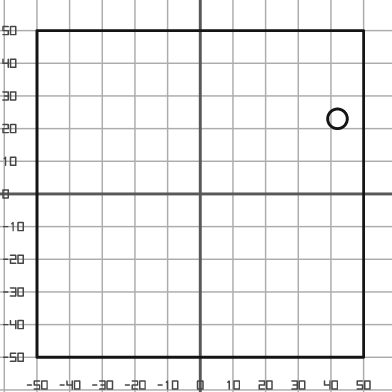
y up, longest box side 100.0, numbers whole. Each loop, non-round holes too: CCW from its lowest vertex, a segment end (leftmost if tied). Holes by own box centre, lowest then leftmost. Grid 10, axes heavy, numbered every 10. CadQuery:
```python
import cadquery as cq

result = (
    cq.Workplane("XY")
    .moveTo(-50.0, -50.0)
    .lineTo(50.0, -50.0)
    .lineTo(50.0, 50.0)
    .lineTo(-50.0, 50.0)
    .close()
    .moveTo(42.0, 23.0)
    .circle(3.0)
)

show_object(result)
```